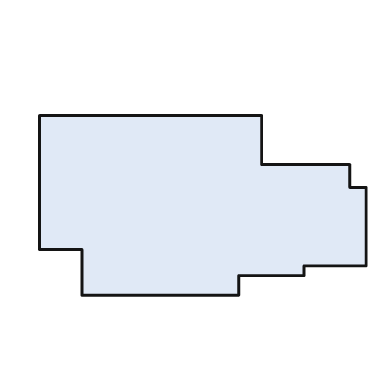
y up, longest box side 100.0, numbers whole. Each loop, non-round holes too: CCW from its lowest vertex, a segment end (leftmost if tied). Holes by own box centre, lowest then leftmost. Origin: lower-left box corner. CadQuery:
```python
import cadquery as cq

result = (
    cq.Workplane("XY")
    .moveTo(13.0, 0.0)
    .lineTo(61.0, 0.0)
    .lineTo(61.0, 6.0)
    .lineTo(81.0, 6.0)
    .lineTo(81.0, 9.0)
    .lineTo(100.0, 9.0)
    .lineTo(100.0, 33.0)
    .lineTo(95.0, 33.0)
    .lineTo(95.0, 40.0)
    .lineTo(68.0, 40.0)
    .lineTo(68.0, 55.0)
    .lineTo(0.0, 55.0)
    .lineTo(0.0, 14.0)
    .lineTo(13.0, 14.0)
    .close()
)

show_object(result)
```